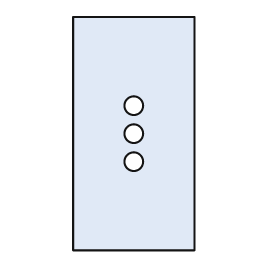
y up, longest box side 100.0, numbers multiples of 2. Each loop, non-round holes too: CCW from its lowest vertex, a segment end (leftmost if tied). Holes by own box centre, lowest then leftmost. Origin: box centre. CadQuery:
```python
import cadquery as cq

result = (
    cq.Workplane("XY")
    .moveTo(-26.0, -50.0)
    .lineTo(26.0, -50.0)
    .lineTo(26.0, 50.0)
    .lineTo(-26.0, 50.0)
    .close()
    .moveTo(0.0, -12.0)
    .circle(4.0)
    .moveTo(0.0, 0.0)
    .circle(4.0)
    .moveTo(0.0, 12.0)
    .circle(4.0)
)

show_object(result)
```